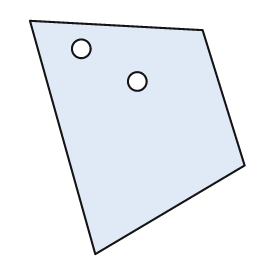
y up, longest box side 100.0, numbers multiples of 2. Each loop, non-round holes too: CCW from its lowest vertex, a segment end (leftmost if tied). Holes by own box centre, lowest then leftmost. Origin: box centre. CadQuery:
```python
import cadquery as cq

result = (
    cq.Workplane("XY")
    .moveTo(-18.0, -50.0)
    .lineTo(46.0, -12.0)
    .lineTo(28.0, 46.0)
    .lineTo(-46.0, 50.0)
    .close()
    .moveTo(0.0, 24.0)
    .circle(4.0)
    .moveTo(-24.0, 38.0)
    .circle(4.0)
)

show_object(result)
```